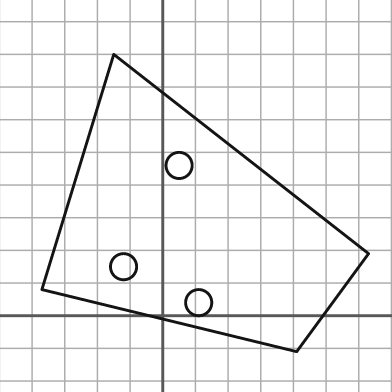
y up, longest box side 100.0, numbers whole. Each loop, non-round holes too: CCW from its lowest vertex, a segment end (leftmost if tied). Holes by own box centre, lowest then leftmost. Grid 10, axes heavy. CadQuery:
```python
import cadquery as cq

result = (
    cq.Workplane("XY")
    .moveTo(41.0, -11.0)
    .lineTo(63.0, 19.0)
    .lineTo(-15.0, 80.0)
    .lineTo(-37.0, 8.0)
    .close()
    .moveTo(11.0, 4.0)
    .circle(4.0)
    .moveTo(-12.0, 15.0)
    .circle(4.0)
    .moveTo(5.0, 46.0)
    .circle(4.0)
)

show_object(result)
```